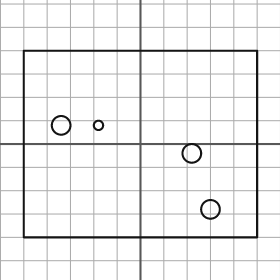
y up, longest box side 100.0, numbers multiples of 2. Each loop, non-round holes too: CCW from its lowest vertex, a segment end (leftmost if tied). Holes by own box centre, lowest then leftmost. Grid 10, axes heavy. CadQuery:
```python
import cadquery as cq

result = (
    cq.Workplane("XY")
    .moveTo(-50.0, -40.0)
    .lineTo(50.0, -40.0)
    .lineTo(50.0, 40.0)
    .lineTo(-50.0, 40.0)
    .close()
    .moveTo(30.0, -28.0)
    .circle(4.0)
    .moveTo(22.0, -4.0)
    .circle(4.0)
    .moveTo(-34.0, 8.0)
    .circle(4.0)
    .moveTo(-18.0, 8.0)
    .circle(2.0)
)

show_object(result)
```